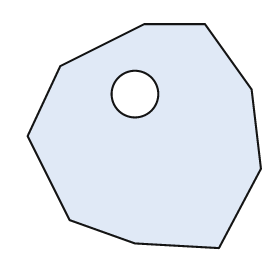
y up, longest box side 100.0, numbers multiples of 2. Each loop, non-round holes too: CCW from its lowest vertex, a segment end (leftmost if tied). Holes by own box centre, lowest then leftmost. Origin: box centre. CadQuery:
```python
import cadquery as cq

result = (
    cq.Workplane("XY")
    .moveTo(32.0, -48.0)
    .lineTo(50.0, -14.0)
    .lineTo(46.0, 20.0)
    .lineTo(26.0, 48.0)
    .lineTo(0.0, 48.0)
    .lineTo(-36.0, 30.0)
    .lineTo(-50.0, 0.0)
    .lineTo(-32.0, -36.0)
    .lineTo(-4.0, -46.0)
    .close()
    .moveTo(-4.0, 18.0)
    .circle(10.0)
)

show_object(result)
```